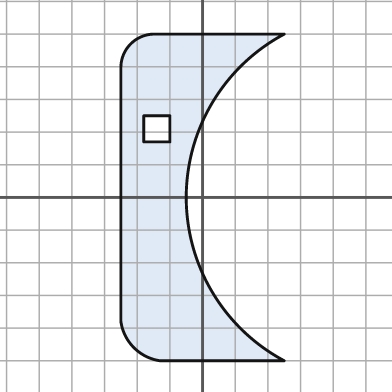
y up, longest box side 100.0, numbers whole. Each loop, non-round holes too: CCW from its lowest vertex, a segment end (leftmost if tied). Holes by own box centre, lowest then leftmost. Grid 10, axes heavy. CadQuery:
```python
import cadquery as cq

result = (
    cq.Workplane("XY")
    .moveTo(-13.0, -50.0)
    .lineTo(25.0, -50.0)
    .threePointArc((-5.0, 0.0), (25.0, 50.0))
    .lineTo(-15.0, 50.0)
    .threePointArc((-22.0, 47.0), (-25.0, 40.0))
    .lineTo(-25.0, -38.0)
    .threePointArc((-21.0, -46.0), (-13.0, -50.0))
    .close()
    .moveTo(-18.0, 17.0)
    .lineTo(-10.0, 17.0)
    .lineTo(-10.0, 25.0)
    .lineTo(-18.0, 25.0)
    .close()
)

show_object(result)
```